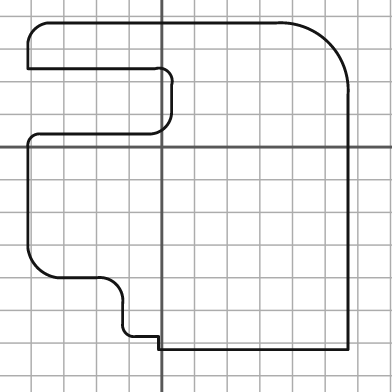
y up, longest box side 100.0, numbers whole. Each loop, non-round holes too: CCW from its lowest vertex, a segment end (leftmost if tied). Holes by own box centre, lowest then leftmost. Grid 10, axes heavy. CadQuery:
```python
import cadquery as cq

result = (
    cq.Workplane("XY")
    .moveTo(-1.0, -62.0)
    .lineTo(57.0, -62.0)
    .lineTo(57.0, 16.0)
    .threePointArc((51.0, 32.0), (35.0, 38.0))
    .lineTo(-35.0, 38.0)
    .threePointArc((-39.0, 36.0), (-41.0, 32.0))
    .lineTo(-41.0, 24.0)
    .lineTo(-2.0, 24.0)
    .threePointArc((2.0, 23.0), (3.0, 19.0))
    .lineTo(3.0, 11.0)
    .threePointArc((1.0, 6.0), (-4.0, 4.0))
    .lineTo(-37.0, 4.0)
    .threePointArc((-40.0, 3.0), (-41.0, 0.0))
    .lineTo(-41.0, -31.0)
    .threePointArc((-38.0, -37.0), (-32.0, -40.0))
    .lineTo(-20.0, -40.0)
    .threePointArc((-14.0, -42.0), (-12.0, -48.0))
    .lineTo(-12.0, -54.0)
    .threePointArc((-11.0, -57.0), (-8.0, -58.0))
    .lineTo(-1.0, -58.0)
    .close()
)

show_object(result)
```